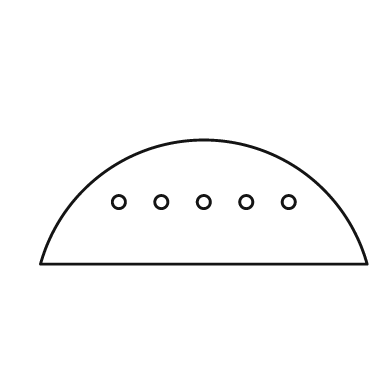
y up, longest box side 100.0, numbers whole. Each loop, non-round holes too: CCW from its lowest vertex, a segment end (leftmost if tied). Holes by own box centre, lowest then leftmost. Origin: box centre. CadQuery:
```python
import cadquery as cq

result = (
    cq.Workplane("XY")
    .moveTo(-50.0, -19.0)
    .lineTo(50.0, -19.0)
    .threePointArc((0.0, 19.0), (-50.0, -19.0))
    .close()
    .moveTo(-26.0, 0.0)
    .circle(2.0)
    .moveTo(-13.0, 0.0)
    .circle(2.0)
    .moveTo(0.0, 0.0)
    .circle(2.0)
    .moveTo(13.0, 0.0)
    .circle(2.0)
    .moveTo(26.0, 0.0)
    .circle(2.0)
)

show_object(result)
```